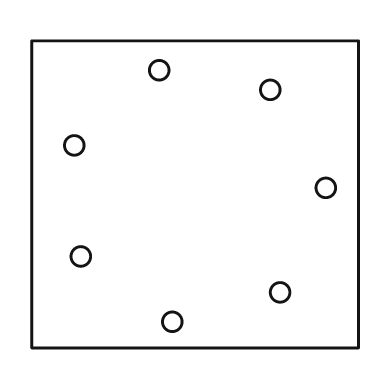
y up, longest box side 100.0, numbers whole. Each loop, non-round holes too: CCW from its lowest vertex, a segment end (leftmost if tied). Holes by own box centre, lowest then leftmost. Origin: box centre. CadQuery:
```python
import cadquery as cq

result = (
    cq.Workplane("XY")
    .moveTo(-50.0, -47.0)
    .lineTo(50.0, -47.0)
    .lineTo(50.0, 47.0)
    .lineTo(-50.0, 47.0)
    .close()
    .moveTo(-7.0, -39.0)
    .circle(3.0)
    .moveTo(26.0, -30.0)
    .circle(3.0)
    .moveTo(-35.0, -19.0)
    .circle(3.0)
    .moveTo(40.0, 2.0)
    .circle(3.0)
    .moveTo(-37.0, 15.0)
    .circle(3.0)
    .moveTo(23.0, 32.0)
    .circle(3.0)
    .moveTo(-11.0, 38.0)
    .circle(3.0)
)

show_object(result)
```